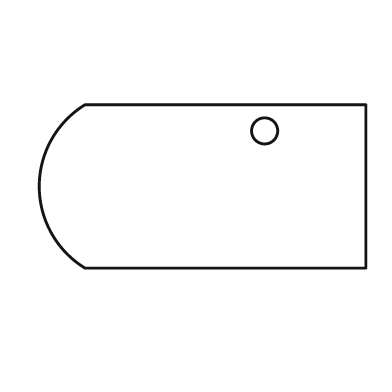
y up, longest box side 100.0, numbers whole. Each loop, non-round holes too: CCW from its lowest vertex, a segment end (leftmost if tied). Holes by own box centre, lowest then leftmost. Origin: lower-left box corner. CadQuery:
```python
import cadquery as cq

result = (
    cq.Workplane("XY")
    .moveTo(14.0, 0.0)
    .lineTo(100.0, 0.0)
    .lineTo(100.0, 50.0)
    .lineTo(14.0, 50.0)
    .threePointArc((0.0, 25.0), (14.0, 0.0))
    .close()
    .moveTo(69.0, 42.0)
    .circle(4.0)
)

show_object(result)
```